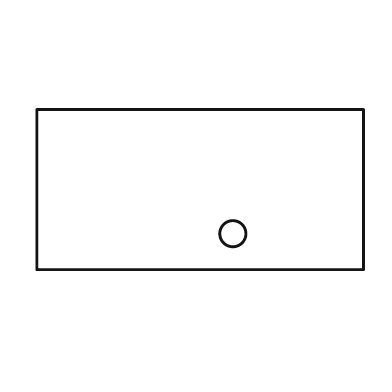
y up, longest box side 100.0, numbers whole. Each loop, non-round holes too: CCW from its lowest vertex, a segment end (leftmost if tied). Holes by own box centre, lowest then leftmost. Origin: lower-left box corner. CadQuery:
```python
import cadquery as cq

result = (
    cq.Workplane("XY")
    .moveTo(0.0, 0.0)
    .lineTo(100.0, 0.0)
    .lineTo(100.0, 49.0)
    .lineTo(0.0, 49.0)
    .close()
    .moveTo(60.0, 11.0)
    .circle(4.0)
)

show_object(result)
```